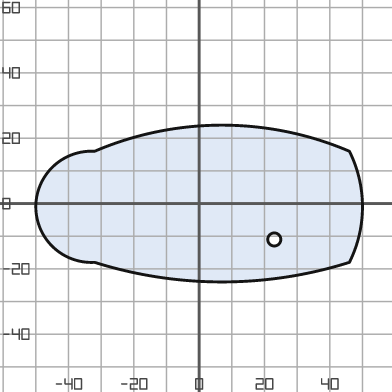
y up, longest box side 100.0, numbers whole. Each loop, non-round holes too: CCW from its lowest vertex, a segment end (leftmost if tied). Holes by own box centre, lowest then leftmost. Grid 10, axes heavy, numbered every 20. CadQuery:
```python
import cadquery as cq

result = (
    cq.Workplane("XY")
    .moveTo(-32.0, -18.0)
    .threePointArc((7.0, -24.0), (46.0, -18.0))
    .threePointArc((50.0, -1.0), (46.0, 16.0))
    .threePointArc((7.0, 24.0), (-32.0, 16.0))
    .threePointArc((-50.0, -1.0), (-32.0, -18.0))
    .close()
    .moveTo(23.0, -11.0)
    .circle(2.0)
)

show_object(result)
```